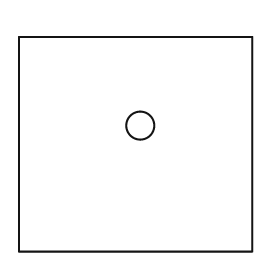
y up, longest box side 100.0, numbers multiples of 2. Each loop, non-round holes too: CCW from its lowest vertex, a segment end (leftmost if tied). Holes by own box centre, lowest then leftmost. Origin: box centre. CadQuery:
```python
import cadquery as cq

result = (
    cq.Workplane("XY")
    .moveTo(-50.0, -46.0)
    .lineTo(50.0, -46.0)
    .lineTo(50.0, 46.0)
    .lineTo(-50.0, 46.0)
    .close()
    .moveTo(2.0, 8.0)
    .circle(6.0)
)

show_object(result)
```